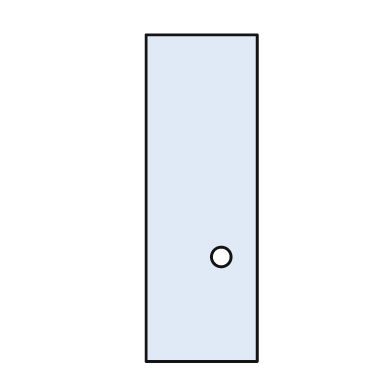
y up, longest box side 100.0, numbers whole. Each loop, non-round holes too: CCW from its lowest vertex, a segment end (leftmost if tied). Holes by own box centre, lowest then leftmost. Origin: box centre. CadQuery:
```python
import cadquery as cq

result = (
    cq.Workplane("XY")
    .moveTo(-17.0, -50.0)
    .lineTo(17.0, -50.0)
    .lineTo(17.0, 50.0)
    .lineTo(-17.0, 50.0)
    .close()
    .moveTo(6.0, -18.0)
    .circle(3.0)
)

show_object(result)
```